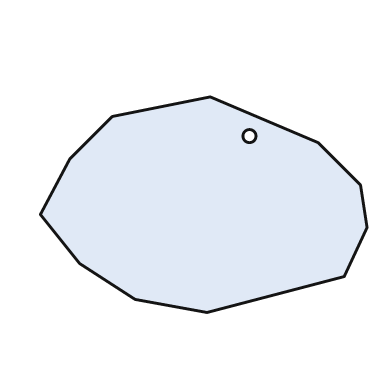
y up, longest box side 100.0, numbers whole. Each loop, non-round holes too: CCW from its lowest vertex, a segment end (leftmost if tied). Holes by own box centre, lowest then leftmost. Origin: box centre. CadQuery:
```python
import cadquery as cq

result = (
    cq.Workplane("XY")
    .moveTo(1.0, -33.0)
    .lineTo(43.0, -22.0)
    .lineTo(50.0, -7.0)
    .lineTo(48.0, 6.0)
    .lineTo(35.0, 19.0)
    .lineTo(2.0, 33.0)
    .lineTo(-28.0, 27.0)
    .lineTo(-41.0, 14.0)
    .lineTo(-50.0, -3.0)
    .lineTo(-38.0, -18.0)
    .lineTo(-21.0, -29.0)
    .close()
    .moveTo(14.0, 21.0)
    .circle(2.0)
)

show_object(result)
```